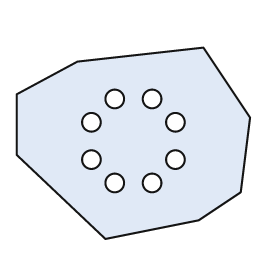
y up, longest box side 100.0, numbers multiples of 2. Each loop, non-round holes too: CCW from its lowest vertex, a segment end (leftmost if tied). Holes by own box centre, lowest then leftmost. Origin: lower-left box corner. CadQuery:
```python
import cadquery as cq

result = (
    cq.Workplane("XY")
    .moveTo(38.0, 0.0)
    .lineTo(78.0, 8.0)
    .lineTo(96.0, 20.0)
    .lineTo(100.0, 52.0)
    .lineTo(80.0, 82.0)
    .lineTo(26.0, 76.0)
    .lineTo(0.0, 62.0)
    .lineTo(0.0, 36.0)
    .close()
    .moveTo(42.0, 24.0)
    .circle(4.0)
    .moveTo(58.0, 24.0)
    .circle(4.0)
    .moveTo(32.0, 34.0)
    .circle(4.0)
    .moveTo(68.0, 34.0)
    .circle(4.0)
    .moveTo(32.0, 50.0)
    .circle(4.0)
    .moveTo(68.0, 50.0)
    .circle(4.0)
    .moveTo(42.0, 60.0)
    .circle(4.0)
    .moveTo(58.0, 60.0)
    .circle(4.0)
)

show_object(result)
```